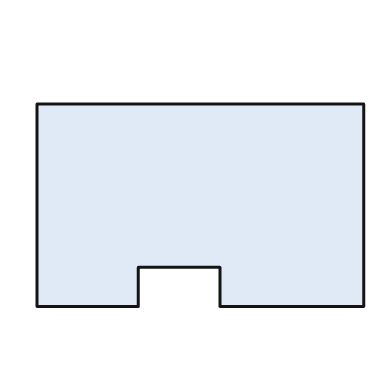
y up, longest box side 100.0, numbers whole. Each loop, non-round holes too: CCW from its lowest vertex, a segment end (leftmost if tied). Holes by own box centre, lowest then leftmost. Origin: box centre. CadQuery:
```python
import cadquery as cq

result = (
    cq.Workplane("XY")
    .moveTo(-50.0, -31.0)
    .lineTo(-19.0, -31.0)
    .lineTo(-19.0, -19.0)
    .lineTo(6.0, -19.0)
    .lineTo(6.0, -31.0)
    .lineTo(50.0, -31.0)
    .lineTo(50.0, 31.0)
    .lineTo(-50.0, 31.0)
    .close()
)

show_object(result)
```